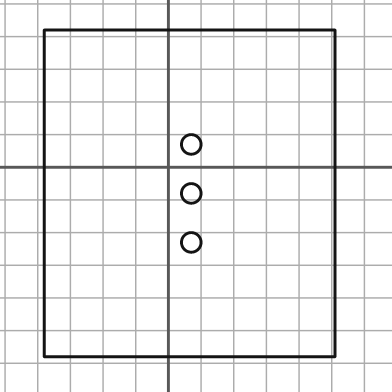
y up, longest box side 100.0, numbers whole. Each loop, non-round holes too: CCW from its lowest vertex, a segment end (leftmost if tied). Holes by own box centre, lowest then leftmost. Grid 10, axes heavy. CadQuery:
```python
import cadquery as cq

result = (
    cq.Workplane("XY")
    .moveTo(-38.0, -58.0)
    .lineTo(51.0, -58.0)
    .lineTo(51.0, 42.0)
    .lineTo(-38.0, 42.0)
    .close()
    .moveTo(7.0, -23.0)
    .circle(3.0)
    .moveTo(7.0, -8.0)
    .circle(3.0)
    .moveTo(7.0, 7.0)
    .circle(3.0)
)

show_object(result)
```